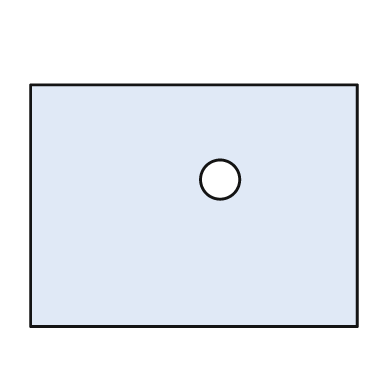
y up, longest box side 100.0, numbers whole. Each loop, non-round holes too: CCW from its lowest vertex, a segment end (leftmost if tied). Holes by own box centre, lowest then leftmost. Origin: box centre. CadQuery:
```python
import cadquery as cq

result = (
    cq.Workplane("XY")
    .moveTo(-50.0, -37.0)
    .lineTo(50.0, -37.0)
    .lineTo(50.0, 37.0)
    .lineTo(-50.0, 37.0)
    .close()
    .moveTo(8.0, 8.0)
    .circle(6.0)
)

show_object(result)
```